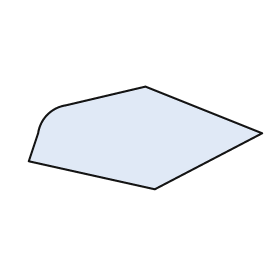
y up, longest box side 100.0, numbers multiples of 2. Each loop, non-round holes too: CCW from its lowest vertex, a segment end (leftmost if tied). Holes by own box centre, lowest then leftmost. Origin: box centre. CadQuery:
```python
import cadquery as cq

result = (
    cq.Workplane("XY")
    .moveTo(4.0, -22.0)
    .lineTo(50.0, 2.0)
    .lineTo(0.0, 22.0)
    .lineTo(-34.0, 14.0)
    .threePointArc((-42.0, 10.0), (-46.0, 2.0))
    .lineTo(-50.0, -10.0)
    .close()
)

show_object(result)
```